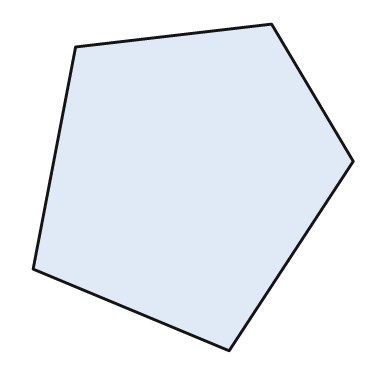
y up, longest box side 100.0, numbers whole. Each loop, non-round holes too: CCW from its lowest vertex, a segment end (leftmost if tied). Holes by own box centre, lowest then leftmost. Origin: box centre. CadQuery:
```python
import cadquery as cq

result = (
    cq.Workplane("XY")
    .moveTo(11.0, -50.0)
    .lineTo(49.0, 8.0)
    .lineTo(24.0, 50.0)
    .lineTo(-36.0, 43.0)
    .lineTo(-49.0, -25.0)
    .close()
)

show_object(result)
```